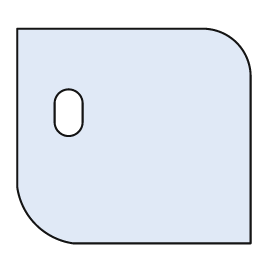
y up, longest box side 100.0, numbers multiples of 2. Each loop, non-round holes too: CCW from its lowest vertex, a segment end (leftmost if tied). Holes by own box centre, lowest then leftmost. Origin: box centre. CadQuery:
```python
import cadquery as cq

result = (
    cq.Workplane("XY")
    .moveTo(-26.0, -46.0)
    .lineTo(50.0, -46.0)
    .lineTo(50.0, 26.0)
    .threePointArc((44.0, 40.0), (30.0, 46.0))
    .lineTo(-50.0, 46.0)
    .lineTo(-50.0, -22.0)
    .threePointArc((-42.0, -38.0), (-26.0, -46.0))
    .close()
    .moveTo(-34.0, 6.0)
    .threePointArc((-28.0, 0.0), (-22.0, 6.0))
    .lineTo(-22.0, 14.0)
    .threePointArc((-28.0, 20.0), (-34.0, 14.0))
    .close()
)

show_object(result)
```